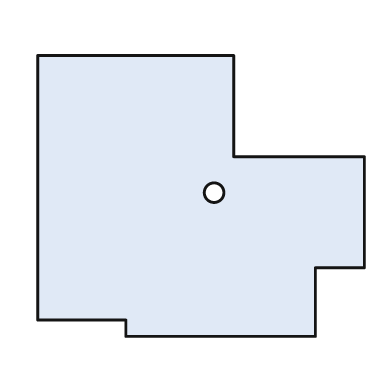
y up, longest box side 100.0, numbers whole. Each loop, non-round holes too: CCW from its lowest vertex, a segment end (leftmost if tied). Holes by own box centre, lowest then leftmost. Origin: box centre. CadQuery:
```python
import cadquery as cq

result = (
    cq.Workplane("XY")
    .moveTo(-23.0, -43.0)
    .lineTo(35.0, -43.0)
    .lineTo(35.0, -22.0)
    .lineTo(50.0, -22.0)
    .lineTo(50.0, 12.0)
    .lineTo(10.0, 12.0)
    .lineTo(10.0, 43.0)
    .lineTo(-50.0, 43.0)
    .lineTo(-50.0, -38.0)
    .lineTo(-23.0, -38.0)
    .close()
    .moveTo(4.0, 1.0)
    .circle(3.0)
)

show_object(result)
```